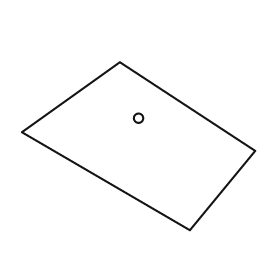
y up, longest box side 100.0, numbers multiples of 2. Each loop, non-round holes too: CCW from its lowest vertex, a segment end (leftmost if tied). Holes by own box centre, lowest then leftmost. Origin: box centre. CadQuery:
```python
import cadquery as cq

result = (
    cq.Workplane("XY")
    .moveTo(22.0, -36.0)
    .lineTo(50.0, -2.0)
    .lineTo(-8.0, 36.0)
    .lineTo(-50.0, 6.0)
    .close()
    .moveTo(0.0, 12.0)
    .circle(2.0)
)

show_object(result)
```